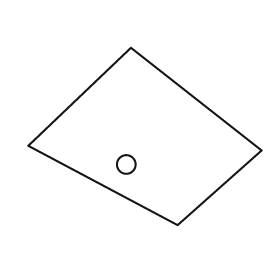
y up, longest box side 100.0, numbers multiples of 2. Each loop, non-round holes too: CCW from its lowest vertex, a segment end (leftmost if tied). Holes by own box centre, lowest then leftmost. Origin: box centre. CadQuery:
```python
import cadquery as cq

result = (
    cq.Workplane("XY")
    .moveTo(14.0, -38.0)
    .lineTo(50.0, -6.0)
    .lineTo(-6.0, 38.0)
    .lineTo(-50.0, -4.0)
    .close()
    .moveTo(-8.0, -12.0)
    .circle(4.0)
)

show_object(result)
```